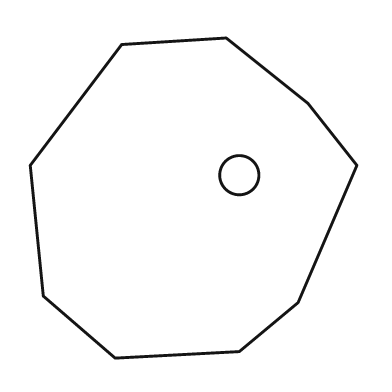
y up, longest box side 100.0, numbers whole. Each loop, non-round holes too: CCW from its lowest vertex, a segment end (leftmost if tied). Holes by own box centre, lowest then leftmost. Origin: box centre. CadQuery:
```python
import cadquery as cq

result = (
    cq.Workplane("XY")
    .moveTo(-24.0, -49.0)
    .lineTo(14.0, -47.0)
    .lineTo(32.0, -32.0)
    .lineTo(50.0, 10.0)
    .lineTo(35.0, 29.0)
    .lineTo(10.0, 49.0)
    .lineTo(-22.0, 47.0)
    .lineTo(-50.0, 10.0)
    .lineTo(-46.0, -30.0)
    .close()
    .moveTo(14.0, 7.0)
    .circle(6.0)
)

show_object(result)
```